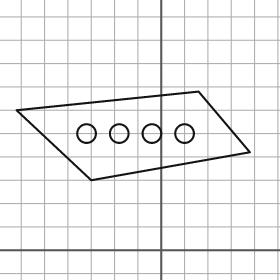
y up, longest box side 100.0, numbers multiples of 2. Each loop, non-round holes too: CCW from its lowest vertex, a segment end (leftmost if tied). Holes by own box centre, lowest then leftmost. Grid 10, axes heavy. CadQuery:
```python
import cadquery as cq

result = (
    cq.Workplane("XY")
    .moveTo(-30.0, 30.0)
    .lineTo(38.0, 42.0)
    .lineTo(16.0, 68.0)
    .lineTo(-62.0, 60.0)
    .close()
    .moveTo(-32.0, 50.0)
    .circle(4.0)
    .moveTo(-18.0, 50.0)
    .circle(4.0)
    .moveTo(-4.0, 50.0)
    .circle(4.0)
    .moveTo(10.0, 50.0)
    .circle(4.0)
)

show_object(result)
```